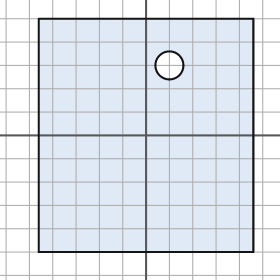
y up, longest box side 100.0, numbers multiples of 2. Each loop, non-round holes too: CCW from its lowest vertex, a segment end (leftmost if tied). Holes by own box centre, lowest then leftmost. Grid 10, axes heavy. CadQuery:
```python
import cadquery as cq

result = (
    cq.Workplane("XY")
    .moveTo(-46.0, -50.0)
    .lineTo(46.0, -50.0)
    .lineTo(46.0, 50.0)
    .lineTo(-46.0, 50.0)
    .close()
    .moveTo(10.0, 30.0)
    .circle(6.0)
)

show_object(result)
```